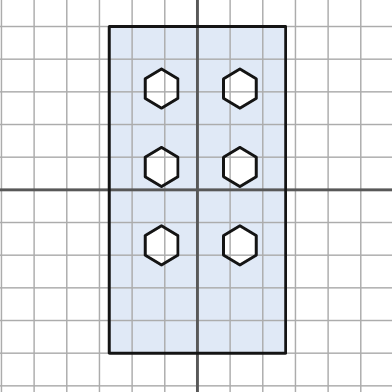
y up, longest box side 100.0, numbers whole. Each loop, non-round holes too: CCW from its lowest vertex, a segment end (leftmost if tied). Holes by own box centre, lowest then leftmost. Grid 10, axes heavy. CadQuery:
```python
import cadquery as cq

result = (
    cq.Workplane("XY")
    .moveTo(-27.0, -50.0)
    .lineTo(27.0, -50.0)
    .lineTo(27.0, 50.0)
    .lineTo(-27.0, 50.0)
    .close()
    .moveTo(-11.0, -23.0)
    .lineTo(-6.0, -20.0)
    .lineTo(-6.0, -14.0)
    .lineTo(-11.0, -11.0)
    .lineTo(-16.0, -14.0)
    .lineTo(-16.0, -20.0)
    .close()
    .moveTo(13.0, -23.0)
    .lineTo(18.0, -20.0)
    .lineTo(18.0, -14.0)
    .lineTo(13.0, -11.0)
    .lineTo(8.0, -14.0)
    .lineTo(8.0, -20.0)
    .close()
    .moveTo(-11.0, 1.0)
    .lineTo(-6.0, 4.0)
    .lineTo(-6.0, 10.0)
    .lineTo(-11.0, 13.0)
    .lineTo(-16.0, 10.0)
    .lineTo(-16.0, 4.0)
    .close()
    .moveTo(13.0, 1.0)
    .lineTo(18.0, 4.0)
    .lineTo(18.0, 10.0)
    .lineTo(13.0, 13.0)
    .lineTo(8.0, 10.0)
    .lineTo(8.0, 4.0)
    .close()
    .moveTo(-11.0, 25.0)
    .lineTo(-6.0, 28.0)
    .lineTo(-6.0, 34.0)
    .lineTo(-11.0, 37.0)
    .lineTo(-16.0, 34.0)
    .lineTo(-16.0, 28.0)
    .close()
    .moveTo(13.0, 25.0)
    .lineTo(18.0, 28.0)
    .lineTo(18.0, 34.0)
    .lineTo(13.0, 37.0)
    .lineTo(8.0, 34.0)
    .lineTo(8.0, 28.0)
    .close()
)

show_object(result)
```